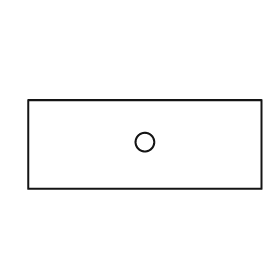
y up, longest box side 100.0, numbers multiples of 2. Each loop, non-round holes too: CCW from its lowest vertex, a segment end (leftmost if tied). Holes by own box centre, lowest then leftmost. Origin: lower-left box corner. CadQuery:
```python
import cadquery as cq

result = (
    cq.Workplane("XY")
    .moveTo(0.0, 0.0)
    .lineTo(100.0, 0.0)
    .lineTo(100.0, 38.0)
    .lineTo(0.0, 38.0)
    .close()
    .moveTo(50.0, 20.0)
    .circle(4.0)
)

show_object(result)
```